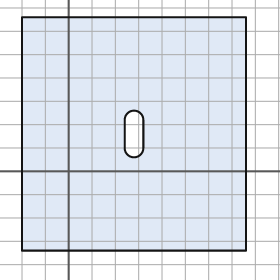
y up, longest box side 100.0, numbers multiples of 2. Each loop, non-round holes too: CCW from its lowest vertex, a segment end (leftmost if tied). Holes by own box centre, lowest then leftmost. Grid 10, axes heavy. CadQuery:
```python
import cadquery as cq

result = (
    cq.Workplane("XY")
    .moveTo(-20.0, -34.0)
    .lineTo(76.0, -34.0)
    .lineTo(76.0, 66.0)
    .lineTo(-20.0, 66.0)
    .close()
    .moveTo(24.0, 10.0)
    .threePointArc((28.0, 6.0), (32.0, 10.0))
    .lineTo(32.0, 22.0)
    .threePointArc((28.0, 26.0), (24.0, 22.0))
    .close()
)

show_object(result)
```